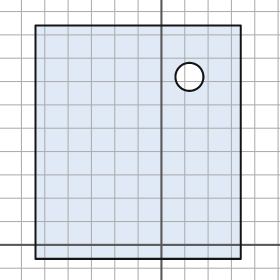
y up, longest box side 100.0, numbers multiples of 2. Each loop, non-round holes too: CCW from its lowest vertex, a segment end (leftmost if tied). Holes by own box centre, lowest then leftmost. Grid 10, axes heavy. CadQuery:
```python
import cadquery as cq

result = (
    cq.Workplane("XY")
    .moveTo(-54.0, -6.0)
    .lineTo(34.0, -6.0)
    .lineTo(34.0, 94.0)
    .lineTo(-54.0, 94.0)
    .close()
    .moveTo(12.0, 72.0)
    .circle(6.0)
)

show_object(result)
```